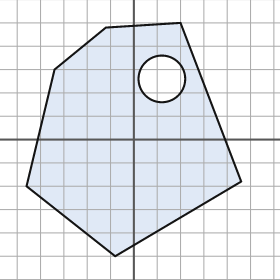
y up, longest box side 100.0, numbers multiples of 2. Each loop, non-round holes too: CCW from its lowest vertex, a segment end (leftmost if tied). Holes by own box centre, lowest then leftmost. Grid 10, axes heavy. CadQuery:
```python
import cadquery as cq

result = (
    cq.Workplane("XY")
    .moveTo(-8.0, -50.0)
    .lineTo(46.0, -18.0)
    .lineTo(20.0, 50.0)
    .lineTo(-12.0, 48.0)
    .lineTo(-34.0, 30.0)
    .lineTo(-46.0, -20.0)
    .close()
    .moveTo(12.0, 26.0)
    .circle(10.0)
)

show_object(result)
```